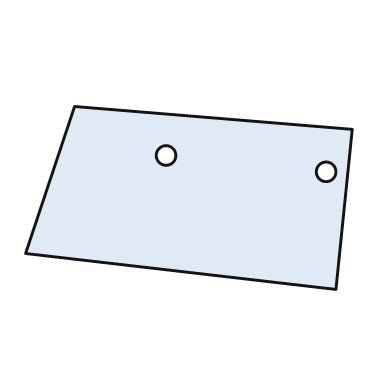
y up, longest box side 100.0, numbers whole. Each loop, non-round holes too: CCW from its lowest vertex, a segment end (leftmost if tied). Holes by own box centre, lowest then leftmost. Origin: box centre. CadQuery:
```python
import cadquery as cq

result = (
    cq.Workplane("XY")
    .moveTo(45.0, -28.0)
    .lineTo(50.0, 21.0)
    .lineTo(-35.0, 28.0)
    .lineTo(-50.0, -17.0)
    .close()
    .moveTo(42.0, 8.0)
    .circle(3.0)
    .moveTo(-7.0, 13.0)
    .circle(3.0)
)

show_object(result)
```